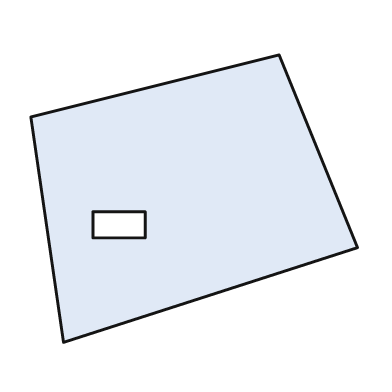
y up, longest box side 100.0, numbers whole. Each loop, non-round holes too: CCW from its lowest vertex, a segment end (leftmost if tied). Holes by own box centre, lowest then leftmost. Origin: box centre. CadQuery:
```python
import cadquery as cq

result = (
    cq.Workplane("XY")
    .moveTo(-40.0, -44.0)
    .lineTo(50.0, -15.0)
    .lineTo(26.0, 44.0)
    .lineTo(-50.0, 25.0)
    .close()
    .moveTo(-31.0, -12.0)
    .lineTo(-15.0, -12.0)
    .lineTo(-15.0, -4.0)
    .lineTo(-31.0, -4.0)
    .close()
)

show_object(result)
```